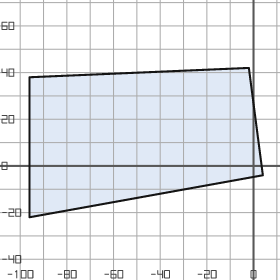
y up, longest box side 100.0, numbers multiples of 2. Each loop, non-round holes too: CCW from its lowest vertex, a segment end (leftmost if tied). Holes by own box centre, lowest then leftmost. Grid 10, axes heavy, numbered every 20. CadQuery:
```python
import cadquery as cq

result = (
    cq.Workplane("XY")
    .moveTo(-96.0, -22.0)
    .lineTo(4.0, -4.0)
    .lineTo(-2.0, 42.0)
    .lineTo(-96.0, 38.0)
    .close()
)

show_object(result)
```